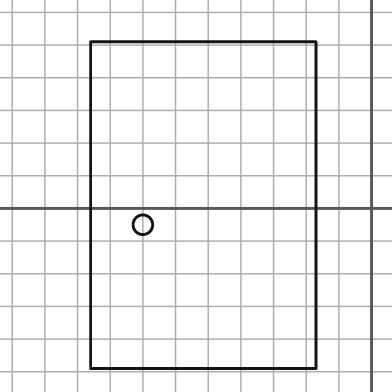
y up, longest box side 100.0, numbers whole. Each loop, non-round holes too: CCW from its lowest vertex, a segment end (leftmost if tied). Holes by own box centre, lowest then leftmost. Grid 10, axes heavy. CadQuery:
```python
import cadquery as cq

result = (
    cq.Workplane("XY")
    .moveTo(-86.0, -49.0)
    .lineTo(-17.0, -49.0)
    .lineTo(-17.0, 51.0)
    .lineTo(-86.0, 51.0)
    .close()
    .moveTo(-70.0, -5.0)
    .circle(3.0)
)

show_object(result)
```